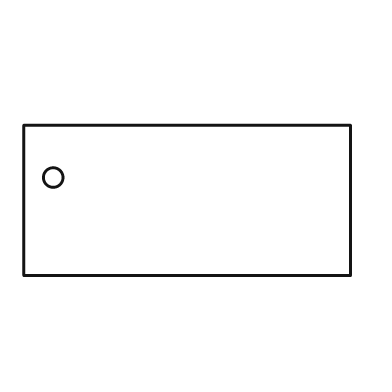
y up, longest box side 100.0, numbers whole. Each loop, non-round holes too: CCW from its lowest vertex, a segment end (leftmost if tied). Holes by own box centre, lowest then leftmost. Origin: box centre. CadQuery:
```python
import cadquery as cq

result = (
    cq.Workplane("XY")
    .moveTo(-50.0, -23.0)
    .lineTo(50.0, -23.0)
    .lineTo(50.0, 23.0)
    .lineTo(-50.0, 23.0)
    .close()
    .moveTo(-41.0, 7.0)
    .circle(3.0)
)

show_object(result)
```